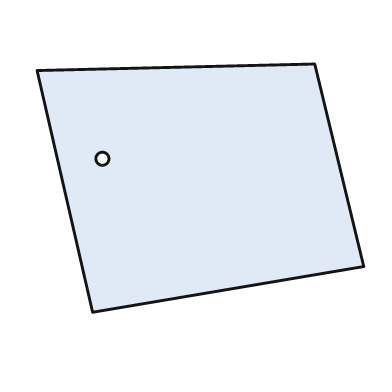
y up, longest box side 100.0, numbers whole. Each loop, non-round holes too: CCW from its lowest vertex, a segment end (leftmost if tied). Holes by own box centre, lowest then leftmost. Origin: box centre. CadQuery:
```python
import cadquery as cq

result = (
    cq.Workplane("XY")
    .moveTo(-33.0, -38.0)
    .lineTo(50.0, -24.0)
    .lineTo(35.0, 38.0)
    .lineTo(-50.0, 36.0)
    .close()
    .moveTo(-30.0, 9.0)
    .circle(2.0)
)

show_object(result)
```